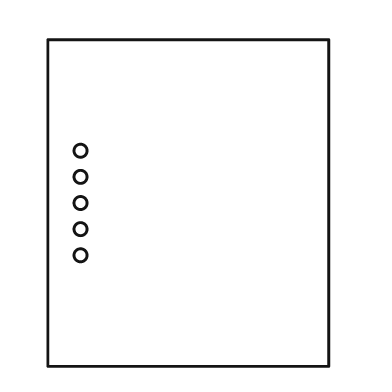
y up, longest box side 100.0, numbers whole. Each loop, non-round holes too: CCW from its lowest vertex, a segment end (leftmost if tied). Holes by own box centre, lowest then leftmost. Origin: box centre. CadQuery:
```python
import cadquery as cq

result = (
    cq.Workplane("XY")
    .moveTo(-43.0, -50.0)
    .lineTo(43.0, -50.0)
    .lineTo(43.0, 50.0)
    .lineTo(-43.0, 50.0)
    .close()
    .moveTo(-33.0, -16.0)
    .circle(2.0)
    .moveTo(-33.0, -8.0)
    .circle(2.0)
    .moveTo(-33.0, 0.0)
    .circle(2.0)
    .moveTo(-33.0, 8.0)
    .circle(2.0)
    .moveTo(-33.0, 16.0)
    .circle(2.0)
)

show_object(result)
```